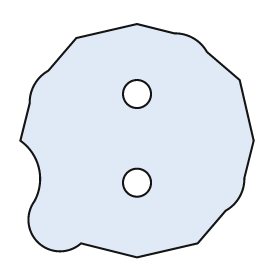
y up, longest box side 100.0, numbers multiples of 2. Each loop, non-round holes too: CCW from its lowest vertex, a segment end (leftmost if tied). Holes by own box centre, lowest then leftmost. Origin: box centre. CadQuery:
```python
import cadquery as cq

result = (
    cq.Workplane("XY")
    .moveTo(0.0, -50.0)
    .lineTo(26.0, -44.0)
    .lineTo(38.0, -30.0)
    .threePointArc((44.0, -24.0), (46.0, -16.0))
    .lineTo(50.0, 0.0)
    .lineTo(44.0, 26.0)
    .lineTo(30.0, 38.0)
    .threePointArc((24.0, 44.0), (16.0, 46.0))
    .lineTo(0.0, 50.0)
    .lineTo(-26.0, 44.0)
    .lineTo(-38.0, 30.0)
    .threePointArc((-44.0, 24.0), (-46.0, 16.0))
    .lineTo(-50.0, 0.0)
    .threePointArc((-42.0, -12.0), (-44.0, -26.0))
    .threePointArc((-42.0, -44.0), (-24.0, -44.0))
    .close()
    .moveTo(0.0, -18.0)
    .circle(6.0)
    .moveTo(0.0, 20.0)
    .circle(6.0)
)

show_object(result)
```